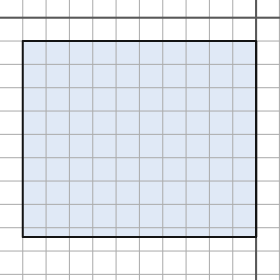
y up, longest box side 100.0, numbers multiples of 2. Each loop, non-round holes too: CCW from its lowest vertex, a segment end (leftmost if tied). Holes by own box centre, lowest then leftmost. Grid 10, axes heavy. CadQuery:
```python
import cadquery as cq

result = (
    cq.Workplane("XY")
    .moveTo(-100.0, -94.0)
    .lineTo(0.0, -94.0)
    .lineTo(0.0, -10.0)
    .lineTo(-100.0, -10.0)
    .close()
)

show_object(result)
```